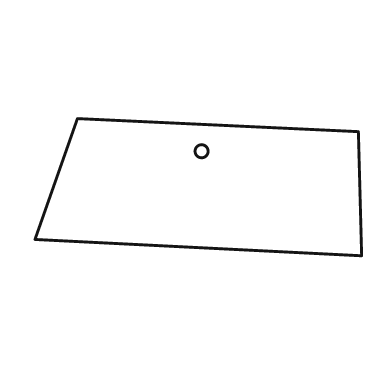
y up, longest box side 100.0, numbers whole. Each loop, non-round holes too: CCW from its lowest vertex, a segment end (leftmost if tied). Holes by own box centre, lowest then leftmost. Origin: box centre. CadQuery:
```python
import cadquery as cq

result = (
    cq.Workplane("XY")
    .moveTo(50.0, -21.0)
    .lineTo(49.0, 17.0)
    .lineTo(-37.0, 21.0)
    .lineTo(-50.0, -16.0)
    .close()
    .moveTo(1.0, 11.0)
    .circle(2.0)
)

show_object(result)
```